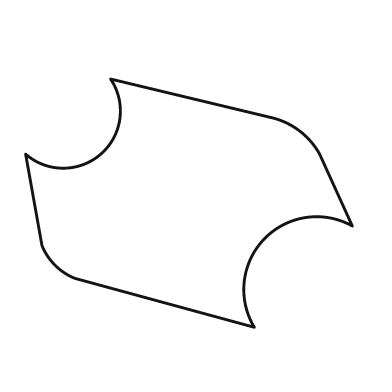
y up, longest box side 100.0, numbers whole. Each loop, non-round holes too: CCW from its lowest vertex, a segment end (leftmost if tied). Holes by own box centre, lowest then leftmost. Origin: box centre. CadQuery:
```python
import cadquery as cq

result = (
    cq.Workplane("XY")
    .moveTo(20.0, -38.0)
    .threePointArc((23.0, -11.0), (50.0, -7.0))
    .lineTo(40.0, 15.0)
    .threePointArc((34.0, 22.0), (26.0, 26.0))
    .lineTo(-24.0, 38.0)
    .threePointArc((-27.0, 15.0), (-50.0, 15.0))
    .lineTo(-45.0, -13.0)
    .threePointArc((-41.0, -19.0), (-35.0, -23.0))
    .close()
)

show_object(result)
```